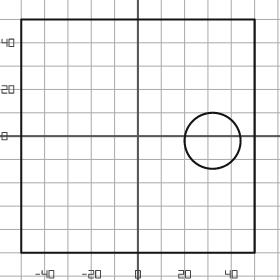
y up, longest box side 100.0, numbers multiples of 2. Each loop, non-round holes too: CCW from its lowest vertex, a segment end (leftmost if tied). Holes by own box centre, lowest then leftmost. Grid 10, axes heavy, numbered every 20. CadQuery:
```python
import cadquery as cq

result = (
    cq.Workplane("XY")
    .moveTo(-50.0, -50.0)
    .lineTo(50.0, -50.0)
    .lineTo(50.0, 50.0)
    .lineTo(-50.0, 50.0)
    .close()
    .moveTo(32.0, -2.0)
    .circle(12.0)
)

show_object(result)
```